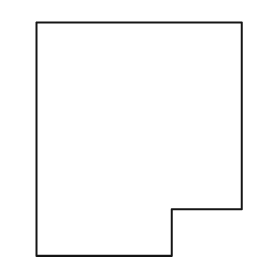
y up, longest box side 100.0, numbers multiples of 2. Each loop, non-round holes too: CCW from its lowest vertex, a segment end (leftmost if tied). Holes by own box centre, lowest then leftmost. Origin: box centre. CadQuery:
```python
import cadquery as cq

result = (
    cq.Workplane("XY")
    .moveTo(-44.0, -50.0)
    .lineTo(14.0, -50.0)
    .lineTo(14.0, -30.0)
    .lineTo(44.0, -30.0)
    .lineTo(44.0, 50.0)
    .lineTo(-44.0, 50.0)
    .close()
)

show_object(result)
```